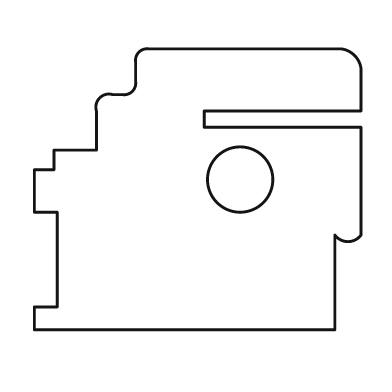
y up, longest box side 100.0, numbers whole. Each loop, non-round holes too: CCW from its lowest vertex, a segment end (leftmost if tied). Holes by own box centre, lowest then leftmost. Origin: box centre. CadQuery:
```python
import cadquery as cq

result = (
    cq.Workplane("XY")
    .moveTo(-50.0, -43.0)
    .lineTo(42.0, -43.0)
    .lineTo(42.0, -14.0)
    .threePointArc((46.0, -16.0), (50.0, -14.0))
    .lineTo(50.0, 19.0)
    .lineTo(2.0, 19.0)
    .lineTo(2.0, 24.0)
    .lineTo(50.0, 24.0)
    .lineTo(50.0, 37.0)
    .threePointArc((48.0, 41.0), (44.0, 43.0))
    .lineTo(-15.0, 43.0)
    .threePointArc((-18.0, 42.0), (-19.0, 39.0))
    .lineTo(-19.0, 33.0)
    .threePointArc((-20.0, 30.0), (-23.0, 29.0))
    .lineTo(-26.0, 29.0)
    .threePointArc((-30.0, 28.0), (-31.0, 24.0))
    .lineTo(-31.0, 12.0)
    .lineTo(-44.0, 12.0)
    .lineTo(-44.0, 6.0)
    .lineTo(-50.0, 6.0)
    .lineTo(-50.0, -7.0)
    .lineTo(-43.0, -7.0)
    .lineTo(-43.0, -36.0)
    .lineTo(-50.0, -36.0)
    .close()
    .moveTo(13.0, 3.0)
    .circle(10.0)
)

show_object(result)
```